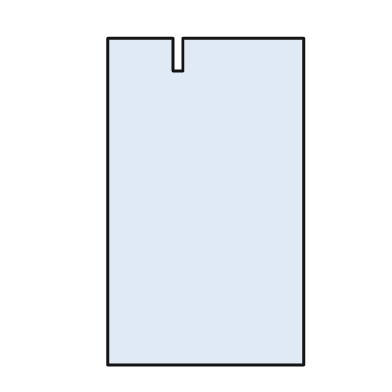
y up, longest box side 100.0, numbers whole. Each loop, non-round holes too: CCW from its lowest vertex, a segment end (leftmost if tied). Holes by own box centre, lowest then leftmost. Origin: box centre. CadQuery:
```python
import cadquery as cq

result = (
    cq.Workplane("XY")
    .moveTo(-30.0, -50.0)
    .lineTo(30.0, -50.0)
    .lineTo(30.0, 50.0)
    .lineTo(-7.0, 50.0)
    .lineTo(-7.0, 40.0)
    .lineTo(-10.0, 40.0)
    .lineTo(-10.0, 50.0)
    .lineTo(-30.0, 50.0)
    .close()
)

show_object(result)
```